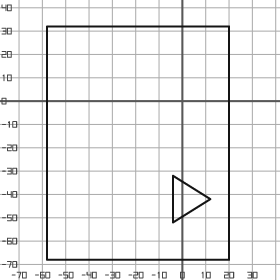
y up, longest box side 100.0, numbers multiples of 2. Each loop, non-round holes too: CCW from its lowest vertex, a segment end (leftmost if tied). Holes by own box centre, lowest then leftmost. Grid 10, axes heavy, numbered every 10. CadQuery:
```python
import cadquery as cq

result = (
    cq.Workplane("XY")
    .moveTo(-58.0, -68.0)
    .lineTo(20.0, -68.0)
    .lineTo(20.0, 32.0)
    .lineTo(-58.0, 32.0)
    .close()
    .moveTo(-4.0, -52.0)
    .lineTo(12.0, -42.0)
    .lineTo(-4.0, -32.0)
    .close()
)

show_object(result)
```